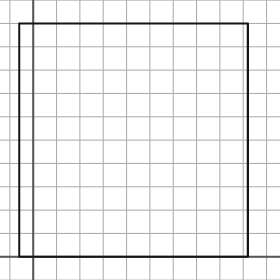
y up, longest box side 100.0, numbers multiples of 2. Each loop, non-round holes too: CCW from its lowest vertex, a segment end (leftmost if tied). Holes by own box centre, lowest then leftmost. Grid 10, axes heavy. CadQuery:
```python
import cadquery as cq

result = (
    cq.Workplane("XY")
    .moveTo(-6.0, 0.0)
    .lineTo(92.0, 0.0)
    .lineTo(92.0, 100.0)
    .lineTo(-6.0, 100.0)
    .close()
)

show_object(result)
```